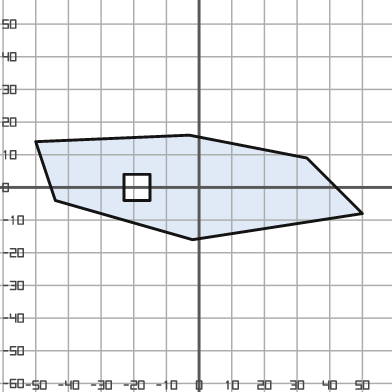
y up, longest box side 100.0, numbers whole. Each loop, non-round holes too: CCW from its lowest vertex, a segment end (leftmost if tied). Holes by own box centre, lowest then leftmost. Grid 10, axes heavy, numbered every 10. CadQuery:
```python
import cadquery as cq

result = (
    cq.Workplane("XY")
    .moveTo(-2.0, -16.0)
    .lineTo(50.0, -8.0)
    .lineTo(33.0, 9.0)
    .lineTo(-3.0, 16.0)
    .lineTo(-50.0, 14.0)
    .lineTo(-44.0, -4.0)
    .close()
    .moveTo(-23.0, -4.0)
    .lineTo(-15.0, -4.0)
    .lineTo(-15.0, 4.0)
    .lineTo(-23.0, 4.0)
    .close()
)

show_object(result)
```